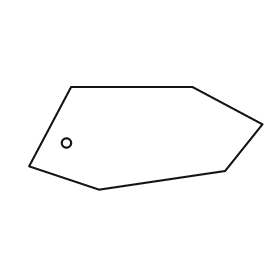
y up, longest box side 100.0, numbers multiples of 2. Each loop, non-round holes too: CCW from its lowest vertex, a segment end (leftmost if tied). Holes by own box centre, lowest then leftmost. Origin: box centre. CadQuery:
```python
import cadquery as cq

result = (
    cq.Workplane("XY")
    .moveTo(-20.0, -22.0)
    .lineTo(34.0, -14.0)
    .lineTo(50.0, 6.0)
    .lineTo(20.0, 22.0)
    .lineTo(-32.0, 22.0)
    .lineTo(-50.0, -12.0)
    .close()
    .moveTo(-34.0, -2.0)
    .circle(2.0)
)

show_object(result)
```